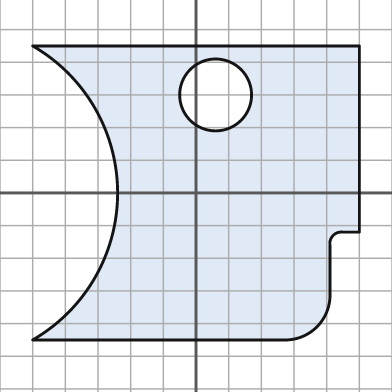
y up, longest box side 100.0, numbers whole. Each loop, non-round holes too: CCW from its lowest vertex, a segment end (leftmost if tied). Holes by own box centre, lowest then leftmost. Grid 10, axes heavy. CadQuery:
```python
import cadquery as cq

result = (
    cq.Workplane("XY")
    .moveTo(-50.0, -45.0)
    .lineTo(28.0, -45.0)
    .threePointArc((37.0, -41.0), (41.0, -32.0))
    .lineTo(41.0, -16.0)
    .threePointArc((42.0, -13.0), (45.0, -12.0))
    .lineTo(50.0, -12.0)
    .lineTo(50.0, 45.0)
    .lineTo(-50.0, 45.0)
    .threePointArc((-24.0, 0.0), (-50.0, -45.0))
    .close()
    .moveTo(6.0, 30.0)
    .circle(11.0)
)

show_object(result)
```